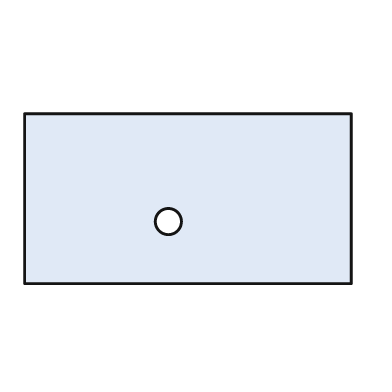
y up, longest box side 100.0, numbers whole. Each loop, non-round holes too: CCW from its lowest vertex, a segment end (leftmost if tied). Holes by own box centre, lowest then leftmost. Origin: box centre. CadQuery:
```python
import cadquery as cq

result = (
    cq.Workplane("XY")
    .moveTo(-50.0, -26.0)
    .lineTo(50.0, -26.0)
    .lineTo(50.0, 26.0)
    .lineTo(-50.0, 26.0)
    .close()
    .moveTo(-6.0, -7.0)
    .circle(4.0)
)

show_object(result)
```